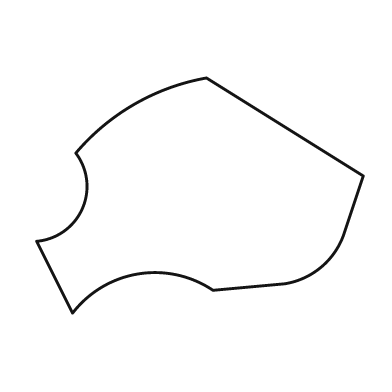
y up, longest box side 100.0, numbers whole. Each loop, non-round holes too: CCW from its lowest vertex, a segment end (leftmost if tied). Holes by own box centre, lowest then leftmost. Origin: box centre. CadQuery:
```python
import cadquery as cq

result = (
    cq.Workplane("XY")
    .moveTo(-39.0, -36.0)
    .threePointArc((-19.0, -24.0), (4.0, -29.0))
    .lineTo(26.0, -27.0)
    .threePointArc((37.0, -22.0), (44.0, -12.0))
    .lineTo(50.0, 6.0)
    .lineTo(2.0, 36.0)
    .threePointArc((-20.0, 28.0), (-38.0, 13.0))
    .threePointArc((-36.0, -4.0), (-50.0, -14.0))
    .close()
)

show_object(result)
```